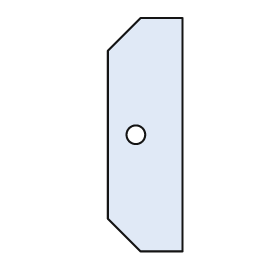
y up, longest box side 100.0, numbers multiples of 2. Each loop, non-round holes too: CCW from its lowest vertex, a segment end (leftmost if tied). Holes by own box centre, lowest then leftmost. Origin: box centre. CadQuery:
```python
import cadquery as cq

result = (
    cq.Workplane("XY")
    .moveTo(-2.0, -50.0)
    .lineTo(16.0, -50.0)
    .lineTo(16.0, 50.0)
    .lineTo(-2.0, 50.0)
    .lineTo(-16.0, 36.0)
    .lineTo(-16.0, -36.0)
    .close()
    .moveTo(-4.0, 0.0)
    .circle(4.0)
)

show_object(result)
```